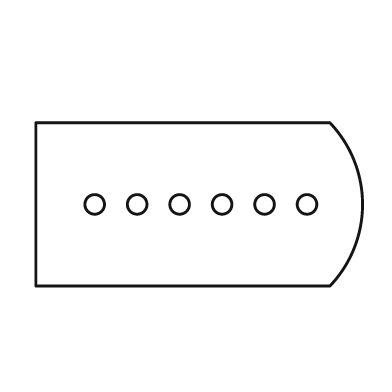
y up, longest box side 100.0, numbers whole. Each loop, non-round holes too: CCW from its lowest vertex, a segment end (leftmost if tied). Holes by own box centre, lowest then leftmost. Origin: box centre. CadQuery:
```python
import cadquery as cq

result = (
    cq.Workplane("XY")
    .moveTo(-50.0, -25.0)
    .lineTo(40.0, -25.0)
    .threePointArc((50.0, 0.0), (40.0, 25.0))
    .lineTo(-50.0, 25.0)
    .close()
    .moveTo(-32.0, 0.0)
    .circle(3.0)
    .moveTo(-19.0, 0.0)
    .circle(3.0)
    .moveTo(-6.0, 0.0)
    .circle(3.0)
    .moveTo(7.0, 0.0)
    .circle(3.0)
    .moveTo(20.0, 0.0)
    .circle(3.0)
    .moveTo(33.0, 0.0)
    .circle(3.0)
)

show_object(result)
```